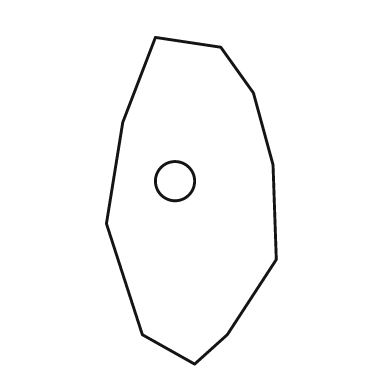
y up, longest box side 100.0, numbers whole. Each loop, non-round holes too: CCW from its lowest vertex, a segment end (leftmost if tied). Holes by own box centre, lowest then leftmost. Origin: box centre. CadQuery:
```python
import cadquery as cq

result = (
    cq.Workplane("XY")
    .moveTo(1.0, -50.0)
    .lineTo(11.0, -41.0)
    .lineTo(26.0, -18.0)
    .lineTo(25.0, 11.0)
    .lineTo(19.0, 33.0)
    .lineTo(9.0, 47.0)
    .lineTo(-11.0, 50.0)
    .lineTo(-21.0, 24.0)
    .lineTo(-26.0, -7.0)
    .lineTo(-15.0, -41.0)
    .close()
    .moveTo(-5.0, 6.0)
    .circle(6.0)
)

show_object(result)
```